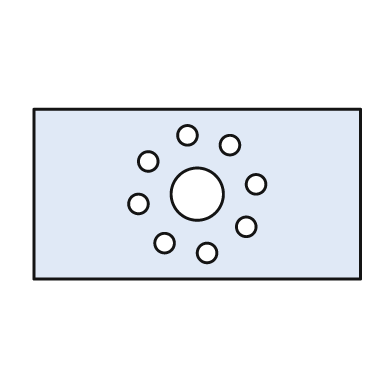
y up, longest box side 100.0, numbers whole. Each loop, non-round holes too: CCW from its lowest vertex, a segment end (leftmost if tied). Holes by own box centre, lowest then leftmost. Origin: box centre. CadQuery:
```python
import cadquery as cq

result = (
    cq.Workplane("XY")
    .moveTo(-50.0, -26.0)
    .lineTo(50.0, -26.0)
    .lineTo(50.0, 26.0)
    .lineTo(-50.0, 26.0)
    .close()
    .moveTo(3.0, -18.0)
    .circle(3.0)
    .moveTo(-10.0, -15.0)
    .circle(3.0)
    .moveTo(15.0, -10.0)
    .circle(3.0)
    .moveTo(-18.0, -3.0)
    .circle(3.0)
    .moveTo(0.0, 0.0)
    .circle(8.0)
    .moveTo(18.0, 3.0)
    .circle(3.0)
    .moveTo(-15.0, 10.0)
    .circle(3.0)
    .moveTo(10.0, 15.0)
    .circle(3.0)
    .moveTo(-3.0, 18.0)
    .circle(3.0)
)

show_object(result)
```